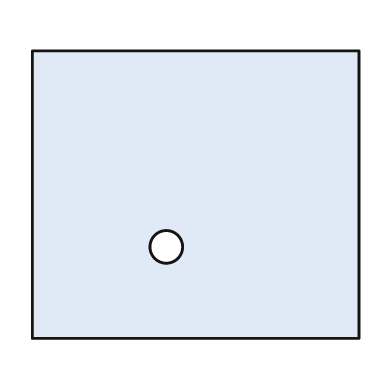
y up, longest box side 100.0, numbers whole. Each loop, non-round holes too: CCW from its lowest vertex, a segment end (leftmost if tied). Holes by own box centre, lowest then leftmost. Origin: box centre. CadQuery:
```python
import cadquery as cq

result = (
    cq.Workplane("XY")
    .moveTo(-50.0, -44.0)
    .lineTo(50.0, -44.0)
    .lineTo(50.0, 44.0)
    .lineTo(-50.0, 44.0)
    .close()
    .moveTo(-9.0, -16.0)
    .circle(5.0)
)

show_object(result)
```